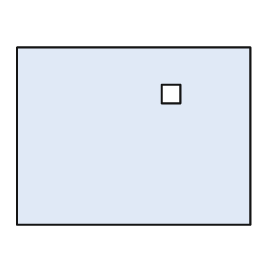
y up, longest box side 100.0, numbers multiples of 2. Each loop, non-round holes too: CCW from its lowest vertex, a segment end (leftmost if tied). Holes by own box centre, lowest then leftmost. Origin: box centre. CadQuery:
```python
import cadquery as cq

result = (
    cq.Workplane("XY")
    .moveTo(-50.0, -38.0)
    .lineTo(50.0, -38.0)
    .lineTo(50.0, 38.0)
    .lineTo(-50.0, 38.0)
    .close()
    .moveTo(12.0, 14.0)
    .lineTo(20.0, 14.0)
    .lineTo(20.0, 22.0)
    .lineTo(12.0, 22.0)
    .close()
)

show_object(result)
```